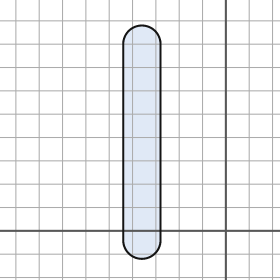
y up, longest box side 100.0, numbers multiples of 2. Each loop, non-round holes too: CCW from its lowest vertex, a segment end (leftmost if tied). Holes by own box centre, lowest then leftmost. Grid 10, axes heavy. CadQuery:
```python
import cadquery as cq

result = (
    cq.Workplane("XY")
    .moveTo(-44.0, -4.0)
    .threePointArc((-36.0, -12.0), (-28.0, -4.0))
    .lineTo(-28.0, 80.0)
    .threePointArc((-36.0, 88.0), (-44.0, 80.0))
    .close()
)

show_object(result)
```